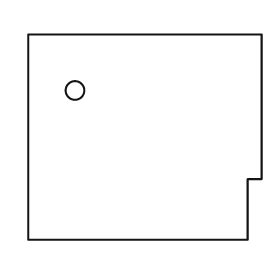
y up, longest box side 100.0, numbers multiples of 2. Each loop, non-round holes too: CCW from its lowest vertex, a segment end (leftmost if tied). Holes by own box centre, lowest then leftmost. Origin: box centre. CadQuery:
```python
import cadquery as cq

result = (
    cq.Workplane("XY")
    .moveTo(-50.0, -44.0)
    .lineTo(44.0, -44.0)
    .lineTo(44.0, -18.0)
    .lineTo(50.0, -18.0)
    .lineTo(50.0, 44.0)
    .lineTo(-50.0, 44.0)
    .close()
    .moveTo(-30.0, 20.0)
    .circle(4.0)
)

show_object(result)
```